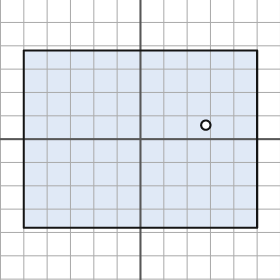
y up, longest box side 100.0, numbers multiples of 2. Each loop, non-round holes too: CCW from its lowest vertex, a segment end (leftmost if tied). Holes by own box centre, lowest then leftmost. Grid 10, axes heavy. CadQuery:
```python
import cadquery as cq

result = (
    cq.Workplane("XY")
    .moveTo(-50.0, -38.0)
    .lineTo(50.0, -38.0)
    .lineTo(50.0, 38.0)
    .lineTo(-50.0, 38.0)
    .close()
    .moveTo(28.0, 6.0)
    .circle(2.0)
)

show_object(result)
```